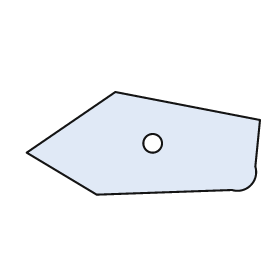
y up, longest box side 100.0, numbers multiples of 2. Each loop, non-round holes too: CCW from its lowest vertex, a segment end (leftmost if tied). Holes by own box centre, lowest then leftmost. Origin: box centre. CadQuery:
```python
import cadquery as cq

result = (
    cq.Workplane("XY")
    .moveTo(-20.0, -22.0)
    .lineTo(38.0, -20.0)
    .threePointArc((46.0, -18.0), (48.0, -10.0))
    .lineTo(50.0, 10.0)
    .lineTo(-12.0, 22.0)
    .lineTo(-50.0, -4.0)
    .close()
    .moveTo(4.0, 0.0)
    .circle(4.0)
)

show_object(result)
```